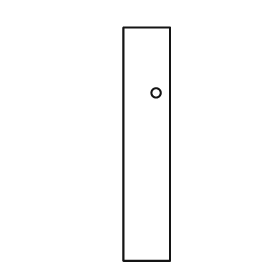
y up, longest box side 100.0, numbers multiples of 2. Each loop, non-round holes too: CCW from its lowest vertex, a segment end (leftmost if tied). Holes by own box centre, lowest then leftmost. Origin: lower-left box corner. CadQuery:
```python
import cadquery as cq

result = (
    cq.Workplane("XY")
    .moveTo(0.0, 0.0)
    .lineTo(20.0, 0.0)
    .lineTo(20.0, 100.0)
    .lineTo(0.0, 100.0)
    .close()
    .moveTo(14.0, 72.0)
    .circle(2.0)
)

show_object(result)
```